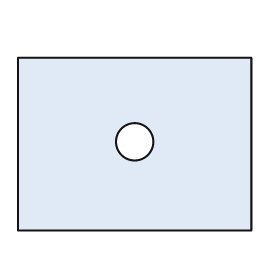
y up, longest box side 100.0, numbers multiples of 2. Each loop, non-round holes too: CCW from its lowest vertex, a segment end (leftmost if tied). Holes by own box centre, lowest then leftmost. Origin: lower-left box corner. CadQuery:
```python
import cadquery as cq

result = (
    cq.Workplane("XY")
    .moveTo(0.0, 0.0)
    .lineTo(100.0, 0.0)
    .lineTo(100.0, 74.0)
    .lineTo(0.0, 74.0)
    .close()
    .moveTo(50.0, 38.0)
    .circle(8.0)
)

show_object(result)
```